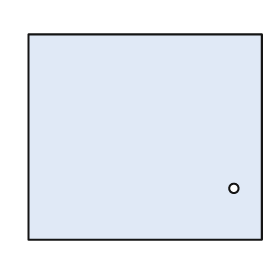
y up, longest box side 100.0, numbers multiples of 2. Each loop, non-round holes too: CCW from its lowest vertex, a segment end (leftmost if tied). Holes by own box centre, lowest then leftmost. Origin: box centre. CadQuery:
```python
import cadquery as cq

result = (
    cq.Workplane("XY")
    .moveTo(-50.0, -44.0)
    .lineTo(50.0, -44.0)
    .lineTo(50.0, 44.0)
    .lineTo(-50.0, 44.0)
    .close()
    .moveTo(38.0, -22.0)
    .circle(2.0)
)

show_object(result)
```